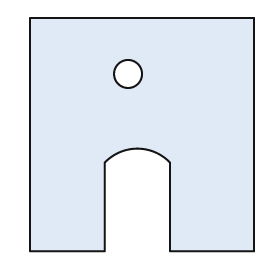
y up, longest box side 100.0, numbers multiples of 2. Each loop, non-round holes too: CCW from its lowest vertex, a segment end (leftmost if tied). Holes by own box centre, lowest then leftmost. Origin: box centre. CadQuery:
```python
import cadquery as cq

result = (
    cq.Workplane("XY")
    .moveTo(-48.0, -50.0)
    .lineTo(-16.0, -50.0)
    .lineTo(-16.0, -12.0)
    .threePointArc((-2.0, -6.0), (12.0, -12.0))
    .lineTo(12.0, -50.0)
    .lineTo(48.0, -50.0)
    .lineTo(48.0, 50.0)
    .lineTo(-48.0, 50.0)
    .close()
    .moveTo(-6.0, 26.0)
    .circle(6.0)
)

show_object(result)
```